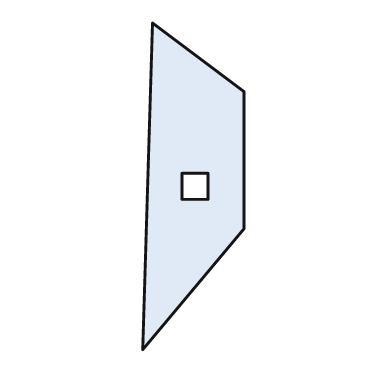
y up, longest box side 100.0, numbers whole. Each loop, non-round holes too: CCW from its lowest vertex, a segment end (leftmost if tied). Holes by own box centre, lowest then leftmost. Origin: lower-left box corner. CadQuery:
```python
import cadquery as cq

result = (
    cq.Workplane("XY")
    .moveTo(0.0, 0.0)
    .lineTo(31.0, 37.0)
    .lineTo(31.0, 79.0)
    .lineTo(3.0, 100.0)
    .close()
    .moveTo(12.0, 46.0)
    .lineTo(20.0, 46.0)
    .lineTo(20.0, 54.0)
    .lineTo(12.0, 54.0)
    .close()
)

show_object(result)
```